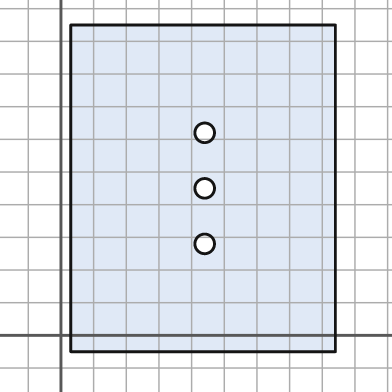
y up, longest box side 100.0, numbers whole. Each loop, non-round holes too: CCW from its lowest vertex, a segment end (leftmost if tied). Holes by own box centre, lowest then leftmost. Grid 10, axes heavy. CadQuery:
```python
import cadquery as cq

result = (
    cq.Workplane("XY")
    .moveTo(3.0, -5.0)
    .lineTo(84.0, -5.0)
    .lineTo(84.0, 95.0)
    .lineTo(3.0, 95.0)
    .close()
    .moveTo(44.0, 28.0)
    .circle(3.0)
    .moveTo(44.0, 45.0)
    .circle(3.0)
    .moveTo(44.0, 62.0)
    .circle(3.0)
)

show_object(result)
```